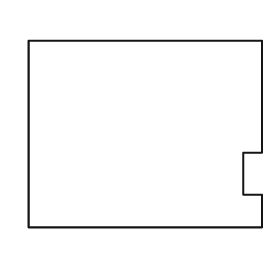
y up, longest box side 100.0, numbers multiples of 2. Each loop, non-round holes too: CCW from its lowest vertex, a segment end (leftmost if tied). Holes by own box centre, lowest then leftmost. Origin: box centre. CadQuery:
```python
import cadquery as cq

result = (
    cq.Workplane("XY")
    .moveTo(-50.0, -40.0)
    .lineTo(50.0, -40.0)
    .lineTo(50.0, -26.0)
    .lineTo(42.0, -26.0)
    .lineTo(42.0, -8.0)
    .lineTo(50.0, -8.0)
    .lineTo(50.0, 40.0)
    .lineTo(-50.0, 40.0)
    .close()
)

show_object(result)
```